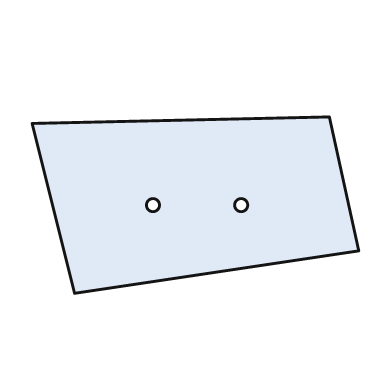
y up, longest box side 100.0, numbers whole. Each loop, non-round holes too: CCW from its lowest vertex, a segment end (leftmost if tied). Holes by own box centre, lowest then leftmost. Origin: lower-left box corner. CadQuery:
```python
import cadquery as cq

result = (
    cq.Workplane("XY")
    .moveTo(13.0, 0.0)
    .lineTo(100.0, 13.0)
    .lineTo(91.0, 54.0)
    .lineTo(0.0, 52.0)
    .close()
    .moveTo(37.0, 27.0)
    .circle(2.0)
    .moveTo(64.0, 27.0)
    .circle(2.0)
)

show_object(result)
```